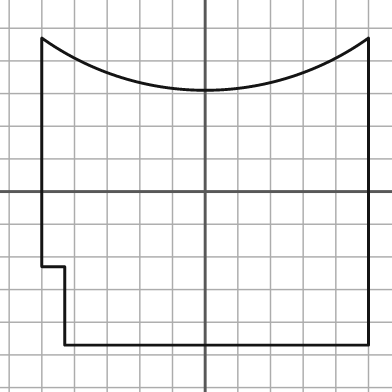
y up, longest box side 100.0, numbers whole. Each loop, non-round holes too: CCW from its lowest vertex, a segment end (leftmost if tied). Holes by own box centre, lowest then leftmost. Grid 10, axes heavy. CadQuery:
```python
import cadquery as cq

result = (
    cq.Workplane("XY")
    .moveTo(-43.0, -47.0)
    .lineTo(50.0, -47.0)
    .lineTo(50.0, 47.0)
    .threePointArc((0.0, 31.0), (-50.0, 47.0))
    .lineTo(-50.0, -23.0)
    .lineTo(-43.0, -23.0)
    .close()
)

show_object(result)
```